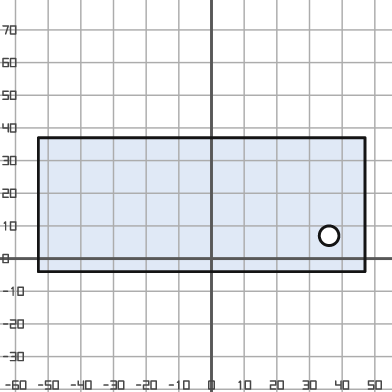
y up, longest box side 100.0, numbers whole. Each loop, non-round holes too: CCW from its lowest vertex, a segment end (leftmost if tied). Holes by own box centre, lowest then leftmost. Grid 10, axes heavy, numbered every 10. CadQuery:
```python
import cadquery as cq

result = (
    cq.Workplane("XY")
    .moveTo(-53.0, -4.0)
    .lineTo(47.0, -4.0)
    .lineTo(47.0, 37.0)
    .lineTo(-53.0, 37.0)
    .close()
    .moveTo(36.0, 7.0)
    .circle(3.0)
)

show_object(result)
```